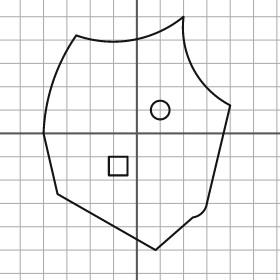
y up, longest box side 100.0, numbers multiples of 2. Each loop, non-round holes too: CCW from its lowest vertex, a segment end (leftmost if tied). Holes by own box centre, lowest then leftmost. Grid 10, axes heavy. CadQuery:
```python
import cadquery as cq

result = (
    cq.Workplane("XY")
    .moveTo(8.0, -50.0)
    .lineTo(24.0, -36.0)
    .threePointArc((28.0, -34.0), (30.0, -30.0))
    .lineTo(40.0, 12.0)
    .threePointArc((24.0, 28.0), (20.0, 50.0))
    .threePointArc((-2.0, 40.0), (-26.0, 42.0))
    .threePointArc((-36.0, 22.0), (-40.0, 0.0))
    .lineTo(-34.0, -26.0)
    .close()
    .moveTo(-12.0, -18.0)
    .lineTo(-4.0, -18.0)
    .lineTo(-4.0, -10.0)
    .lineTo(-12.0, -10.0)
    .close()
    .moveTo(10.0, 10.0)
    .circle(4.0)
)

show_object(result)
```